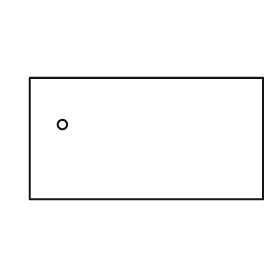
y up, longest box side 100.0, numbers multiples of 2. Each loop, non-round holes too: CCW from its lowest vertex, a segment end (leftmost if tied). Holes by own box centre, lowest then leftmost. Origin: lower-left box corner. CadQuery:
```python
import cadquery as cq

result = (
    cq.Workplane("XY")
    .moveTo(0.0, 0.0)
    .lineTo(100.0, 0.0)
    .lineTo(100.0, 52.0)
    .lineTo(0.0, 52.0)
    .close()
    .moveTo(14.0, 32.0)
    .circle(2.0)
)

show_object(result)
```